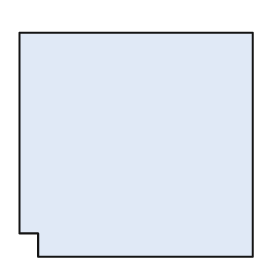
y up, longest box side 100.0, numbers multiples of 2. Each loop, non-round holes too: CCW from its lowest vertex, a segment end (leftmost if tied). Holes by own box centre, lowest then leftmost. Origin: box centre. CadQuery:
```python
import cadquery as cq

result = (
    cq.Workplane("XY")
    .moveTo(-42.0, -48.0)
    .lineTo(50.0, -48.0)
    .lineTo(50.0, 48.0)
    .lineTo(-50.0, 48.0)
    .lineTo(-50.0, -38.0)
    .lineTo(-42.0, -38.0)
    .close()
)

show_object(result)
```